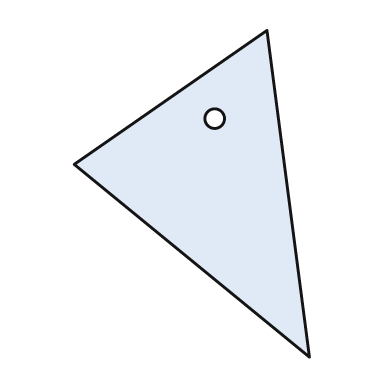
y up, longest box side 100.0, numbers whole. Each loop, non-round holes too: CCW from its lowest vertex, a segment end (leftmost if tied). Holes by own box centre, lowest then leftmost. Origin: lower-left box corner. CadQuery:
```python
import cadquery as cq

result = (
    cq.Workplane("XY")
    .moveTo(72.0, 0.0)
    .lineTo(59.0, 100.0)
    .lineTo(0.0, 59.0)
    .close()
    .moveTo(43.0, 73.0)
    .circle(3.0)
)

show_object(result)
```